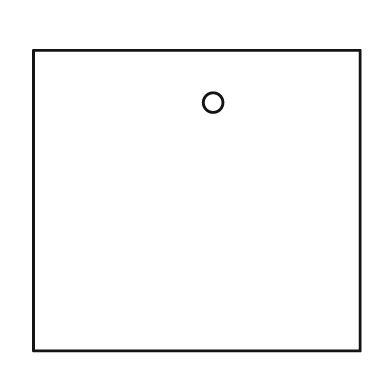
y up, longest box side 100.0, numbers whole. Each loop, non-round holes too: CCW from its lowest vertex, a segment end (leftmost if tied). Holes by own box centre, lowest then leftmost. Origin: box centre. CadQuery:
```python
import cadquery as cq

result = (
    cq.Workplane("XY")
    .moveTo(-50.0, -46.0)
    .lineTo(50.0, -46.0)
    .lineTo(50.0, 46.0)
    .lineTo(-50.0, 46.0)
    .close()
    .moveTo(5.0, 30.0)
    .circle(3.0)
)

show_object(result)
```